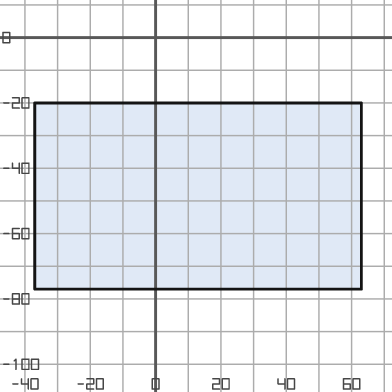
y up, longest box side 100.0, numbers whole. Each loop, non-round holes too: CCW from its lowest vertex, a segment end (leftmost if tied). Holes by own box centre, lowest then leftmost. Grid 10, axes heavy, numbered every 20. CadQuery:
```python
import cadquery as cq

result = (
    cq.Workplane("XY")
    .moveTo(-37.0, -77.0)
    .lineTo(63.0, -77.0)
    .lineTo(63.0, -20.0)
    .lineTo(-37.0, -20.0)
    .close()
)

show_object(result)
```